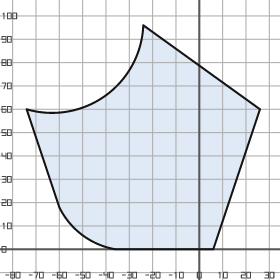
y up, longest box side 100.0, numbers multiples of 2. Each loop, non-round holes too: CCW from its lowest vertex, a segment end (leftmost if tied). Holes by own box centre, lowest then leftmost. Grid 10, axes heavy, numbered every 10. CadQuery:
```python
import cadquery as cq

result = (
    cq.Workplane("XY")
    .moveTo(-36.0, 0.0)
    .lineTo(6.0, 0.0)
    .lineTo(26.0, 60.0)
    .lineTo(-24.0, 96.0)
    .threePointArc((-40.0, 66.0), (-74.0, 60.0))
    .lineTo(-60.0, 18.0)
    .threePointArc((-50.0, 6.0), (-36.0, 0.0))
    .close()
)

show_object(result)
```